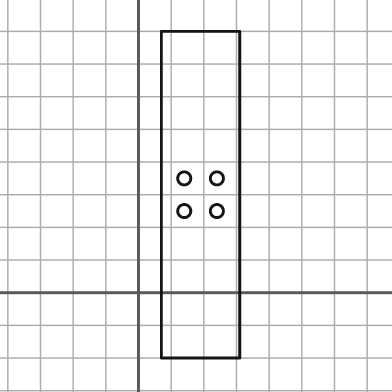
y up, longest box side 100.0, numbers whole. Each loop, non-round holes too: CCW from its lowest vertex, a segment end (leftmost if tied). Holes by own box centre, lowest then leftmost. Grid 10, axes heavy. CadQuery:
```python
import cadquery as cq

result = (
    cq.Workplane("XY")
    .moveTo(7.0, -20.0)
    .lineTo(31.0, -20.0)
    .lineTo(31.0, 80.0)
    .lineTo(7.0, 80.0)
    .close()
    .moveTo(14.0, 25.0)
    .circle(2.0)
    .moveTo(24.0, 25.0)
    .circle(2.0)
    .moveTo(14.0, 35.0)
    .circle(2.0)
    .moveTo(24.0, 35.0)
    .circle(2.0)
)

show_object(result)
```